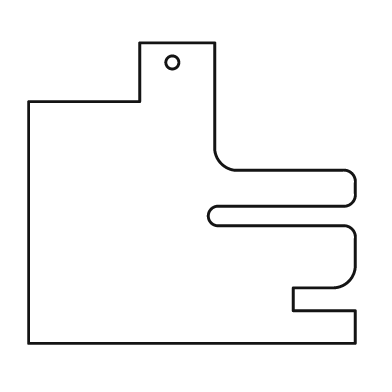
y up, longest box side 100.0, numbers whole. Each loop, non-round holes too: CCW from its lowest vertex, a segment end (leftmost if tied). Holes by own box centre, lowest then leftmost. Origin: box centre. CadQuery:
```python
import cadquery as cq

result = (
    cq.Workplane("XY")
    .moveTo(-50.0, -46.0)
    .lineTo(50.0, -46.0)
    .lineTo(50.0, -36.0)
    .lineTo(31.0, -36.0)
    .lineTo(31.0, -29.0)
    .lineTo(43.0, -29.0)
    .threePointArc((48.0, -27.0), (50.0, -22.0))
    .lineTo(50.0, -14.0)
    .threePointArc((49.0, -11.0), (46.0, -10.0))
    .lineTo(8.0, -10.0)
    .threePointArc((5.0, -7.0), (8.0, -4.0))
    .lineTo(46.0, -4.0)
    .threePointArc((49.0, -3.0), (50.0, 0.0))
    .lineTo(50.0, 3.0)
    .threePointArc((49.0, 6.0), (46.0, 7.0))
    .lineTo(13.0, 7.0)
    .threePointArc((9.0, 9.0), (7.0, 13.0))
    .lineTo(7.0, 46.0)
    .lineTo(-16.0, 46.0)
    .lineTo(-16.0, 28.0)
    .lineTo(-50.0, 28.0)
    .close()
    .moveTo(-6.0, 40.0)
    .circle(2.0)
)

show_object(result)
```